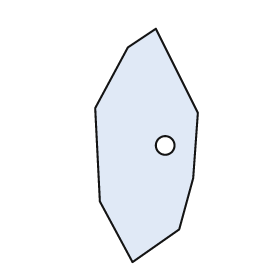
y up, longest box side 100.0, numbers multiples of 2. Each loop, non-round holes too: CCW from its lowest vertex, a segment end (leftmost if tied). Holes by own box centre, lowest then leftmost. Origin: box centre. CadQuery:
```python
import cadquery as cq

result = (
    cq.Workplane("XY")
    .moveTo(-6.0, -50.0)
    .lineTo(14.0, -36.0)
    .lineTo(20.0, -14.0)
    .lineTo(22.0, 14.0)
    .lineTo(4.0, 50.0)
    .lineTo(-8.0, 42.0)
    .lineTo(-22.0, 16.0)
    .lineTo(-20.0, -24.0)
    .close()
    .moveTo(8.0, 0.0)
    .circle(4.0)
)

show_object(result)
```